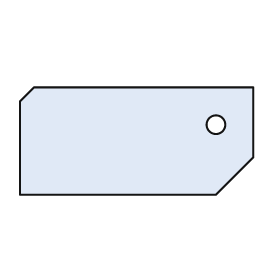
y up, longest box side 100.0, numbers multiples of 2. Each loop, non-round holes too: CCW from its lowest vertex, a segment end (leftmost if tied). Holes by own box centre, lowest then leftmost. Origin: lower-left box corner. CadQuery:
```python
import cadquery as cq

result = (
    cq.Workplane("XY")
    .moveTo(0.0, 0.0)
    .lineTo(84.0, 0.0)
    .lineTo(100.0, 16.0)
    .lineTo(100.0, 46.0)
    .lineTo(6.0, 46.0)
    .lineTo(0.0, 40.0)
    .close()
    .moveTo(84.0, 30.0)
    .circle(4.0)
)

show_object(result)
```